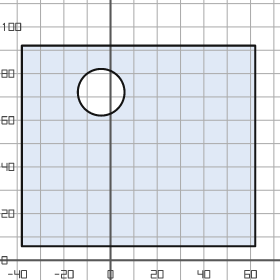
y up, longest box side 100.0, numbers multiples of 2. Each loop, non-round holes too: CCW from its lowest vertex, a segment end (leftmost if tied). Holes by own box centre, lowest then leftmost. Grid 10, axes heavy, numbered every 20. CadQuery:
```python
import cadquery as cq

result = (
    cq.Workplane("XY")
    .moveTo(-38.0, 6.0)
    .lineTo(62.0, 6.0)
    .lineTo(62.0, 92.0)
    .lineTo(-38.0, 92.0)
    .close()
    .moveTo(-4.0, 72.0)
    .circle(10.0)
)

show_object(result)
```